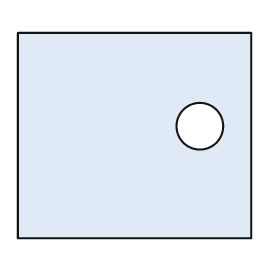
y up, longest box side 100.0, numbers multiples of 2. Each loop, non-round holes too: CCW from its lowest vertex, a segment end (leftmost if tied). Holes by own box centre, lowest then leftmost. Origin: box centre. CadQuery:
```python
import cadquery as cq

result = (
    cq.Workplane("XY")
    .moveTo(-50.0, -44.0)
    .lineTo(50.0, -44.0)
    .lineTo(50.0, 44.0)
    .lineTo(-50.0, 44.0)
    .close()
    .moveTo(28.0, 4.0)
    .circle(10.0)
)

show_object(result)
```